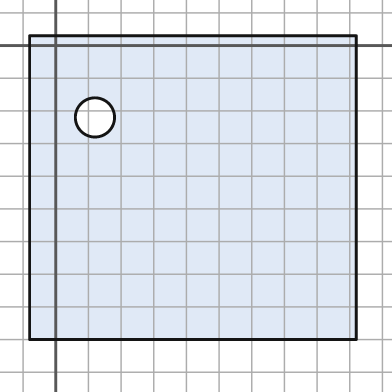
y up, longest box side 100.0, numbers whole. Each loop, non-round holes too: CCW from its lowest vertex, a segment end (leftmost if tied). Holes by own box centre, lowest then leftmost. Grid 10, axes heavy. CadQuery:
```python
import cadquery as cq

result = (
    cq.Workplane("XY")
    .moveTo(-8.0, -90.0)
    .lineTo(92.0, -90.0)
    .lineTo(92.0, 3.0)
    .lineTo(-8.0, 3.0)
    .close()
    .moveTo(12.0, -22.0)
    .circle(6.0)
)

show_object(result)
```